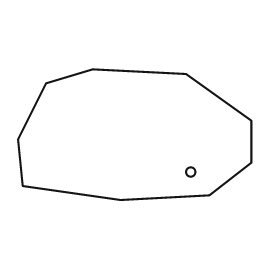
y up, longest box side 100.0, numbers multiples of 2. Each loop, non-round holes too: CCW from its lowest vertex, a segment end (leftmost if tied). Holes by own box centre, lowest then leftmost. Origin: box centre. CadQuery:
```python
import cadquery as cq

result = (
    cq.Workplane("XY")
    .moveTo(-6.0, -28.0)
    .lineTo(32.0, -26.0)
    .lineTo(50.0, -12.0)
    .lineTo(50.0, 6.0)
    .lineTo(22.0, 26.0)
    .lineTo(-18.0, 28.0)
    .lineTo(-38.0, 22.0)
    .lineTo(-50.0, -2.0)
    .lineTo(-48.0, -22.0)
    .close()
    .moveTo(24.0, -16.0)
    .circle(2.0)
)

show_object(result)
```